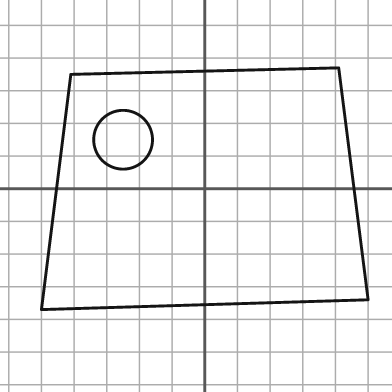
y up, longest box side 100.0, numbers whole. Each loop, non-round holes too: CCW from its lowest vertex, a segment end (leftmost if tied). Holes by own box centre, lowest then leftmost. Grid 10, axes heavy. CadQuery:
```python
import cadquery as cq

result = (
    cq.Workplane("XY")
    .moveTo(-50.0, -37.0)
    .lineTo(50.0, -34.0)
    .lineTo(41.0, 37.0)
    .lineTo(-41.0, 35.0)
    .close()
    .moveTo(-25.0, 15.0)
    .circle(9.0)
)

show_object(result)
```